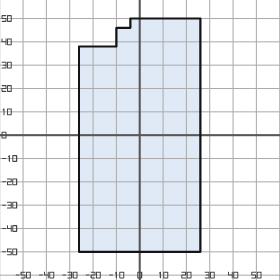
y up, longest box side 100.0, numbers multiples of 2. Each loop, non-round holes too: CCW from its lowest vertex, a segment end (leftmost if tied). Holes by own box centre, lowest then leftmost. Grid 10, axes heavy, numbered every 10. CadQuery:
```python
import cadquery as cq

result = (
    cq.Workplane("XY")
    .moveTo(-26.0, -50.0)
    .lineTo(26.0, -50.0)
    .lineTo(26.0, 50.0)
    .lineTo(-4.0, 50.0)
    .lineTo(-4.0, 46.0)
    .lineTo(-10.0, 46.0)
    .lineTo(-10.0, 38.0)
    .lineTo(-26.0, 38.0)
    .close()
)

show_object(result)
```